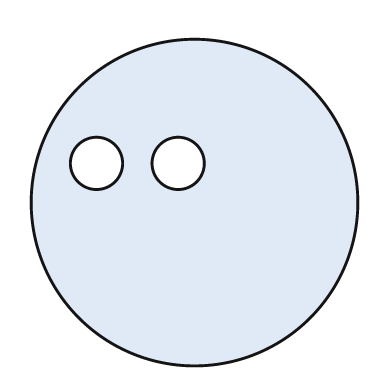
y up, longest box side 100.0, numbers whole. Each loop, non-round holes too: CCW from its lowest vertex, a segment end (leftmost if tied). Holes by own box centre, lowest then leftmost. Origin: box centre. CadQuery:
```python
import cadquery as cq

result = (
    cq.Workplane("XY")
    .moveTo(0.0, 0.0)
    .circle(50.0)
    .moveTo(-30.0, 12.0)
    .circle(8.0)
    .moveTo(-5.0, 12.0)
    .circle(8.0)
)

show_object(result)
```